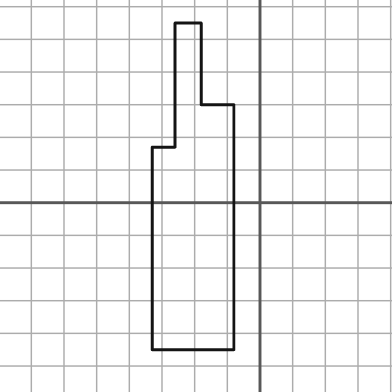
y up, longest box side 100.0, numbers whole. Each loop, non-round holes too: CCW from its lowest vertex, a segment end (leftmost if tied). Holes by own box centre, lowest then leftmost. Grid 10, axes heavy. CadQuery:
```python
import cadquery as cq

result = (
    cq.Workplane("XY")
    .moveTo(-33.0, -45.0)
    .lineTo(-8.0, -45.0)
    .lineTo(-8.0, 30.0)
    .lineTo(-18.0, 30.0)
    .lineTo(-18.0, 55.0)
    .lineTo(-26.0, 55.0)
    .lineTo(-26.0, 17.0)
    .lineTo(-33.0, 17.0)
    .close()
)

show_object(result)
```